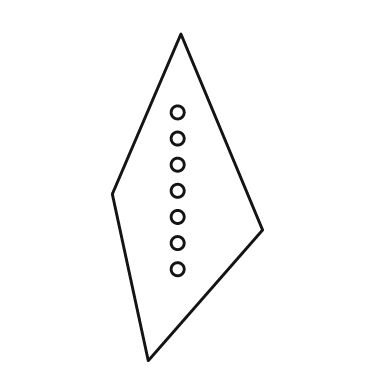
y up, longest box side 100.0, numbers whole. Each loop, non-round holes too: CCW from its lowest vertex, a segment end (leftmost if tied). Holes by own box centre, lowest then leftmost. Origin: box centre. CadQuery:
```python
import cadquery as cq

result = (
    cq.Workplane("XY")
    .moveTo(-12.0, -50.0)
    .lineTo(23.0, -10.0)
    .lineTo(-2.0, 50.0)
    .lineTo(-23.0, 1.0)
    .close()
    .moveTo(-3.0, -22.0)
    .circle(2.0)
    .moveTo(-3.0, -14.0)
    .circle(2.0)
    .moveTo(-3.0, -6.0)
    .circle(2.0)
    .moveTo(-3.0, 2.0)
    .circle(2.0)
    .moveTo(-3.0, 10.0)
    .circle(2.0)
    .moveTo(-3.0, 18.0)
    .circle(2.0)
    .moveTo(-3.0, 26.0)
    .circle(2.0)
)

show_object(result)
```